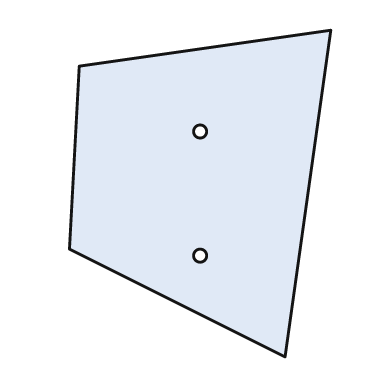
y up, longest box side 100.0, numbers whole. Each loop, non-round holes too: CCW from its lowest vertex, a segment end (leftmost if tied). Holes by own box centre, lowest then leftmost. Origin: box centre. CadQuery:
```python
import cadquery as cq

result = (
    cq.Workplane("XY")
    .moveTo(26.0, -50.0)
    .lineTo(40.0, 50.0)
    .lineTo(-37.0, 39.0)
    .lineTo(-40.0, -17.0)
    .close()
    .moveTo(0.0, -19.0)
    .circle(2.0)
    .moveTo(0.0, 19.0)
    .circle(2.0)
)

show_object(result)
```